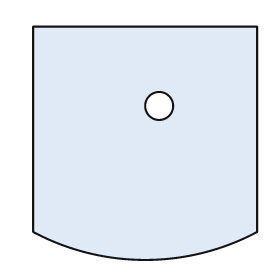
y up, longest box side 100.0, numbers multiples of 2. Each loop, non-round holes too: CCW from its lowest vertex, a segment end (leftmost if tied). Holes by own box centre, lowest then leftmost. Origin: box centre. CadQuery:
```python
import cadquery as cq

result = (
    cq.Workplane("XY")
    .moveTo(-48.0, -38.0)
    .threePointArc((0.0, -50.0), (48.0, -38.0))
    .lineTo(48.0, 50.0)
    .lineTo(-48.0, 50.0)
    .close()
    .moveTo(6.0, 16.0)
    .circle(6.0)
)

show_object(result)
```